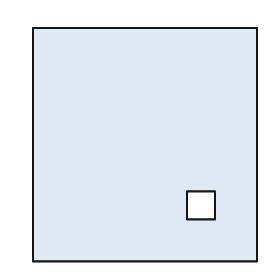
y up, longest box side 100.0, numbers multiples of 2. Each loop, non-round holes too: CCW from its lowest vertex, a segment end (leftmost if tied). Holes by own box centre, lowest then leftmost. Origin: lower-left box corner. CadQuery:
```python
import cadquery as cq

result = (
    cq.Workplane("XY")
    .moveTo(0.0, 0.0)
    .lineTo(96.0, 0.0)
    .lineTo(96.0, 100.0)
    .lineTo(0.0, 100.0)
    .close()
    .moveTo(66.0, 18.0)
    .lineTo(78.0, 18.0)
    .lineTo(78.0, 30.0)
    .lineTo(66.0, 30.0)
    .close()
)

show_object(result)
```